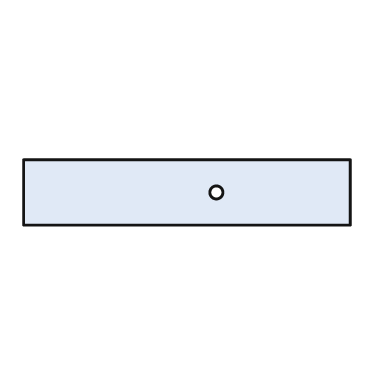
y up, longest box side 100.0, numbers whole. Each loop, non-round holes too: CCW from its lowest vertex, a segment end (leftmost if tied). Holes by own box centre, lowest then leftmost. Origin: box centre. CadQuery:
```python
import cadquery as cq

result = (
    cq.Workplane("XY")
    .moveTo(-50.0, -10.0)
    .lineTo(50.0, -10.0)
    .lineTo(50.0, 10.0)
    .lineTo(-50.0, 10.0)
    .close()
    .moveTo(9.0, 0.0)
    .circle(2.0)
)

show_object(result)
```